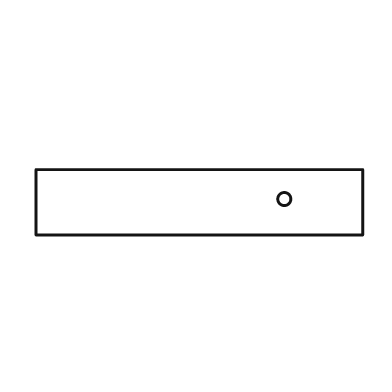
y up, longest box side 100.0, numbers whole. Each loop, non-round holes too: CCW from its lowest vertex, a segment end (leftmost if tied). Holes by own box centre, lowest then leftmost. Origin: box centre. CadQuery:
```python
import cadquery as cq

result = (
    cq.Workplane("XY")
    .moveTo(-50.0, -10.0)
    .lineTo(50.0, -10.0)
    .lineTo(50.0, 10.0)
    .lineTo(-50.0, 10.0)
    .close()
    .moveTo(26.0, 1.0)
    .circle(2.0)
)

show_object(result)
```